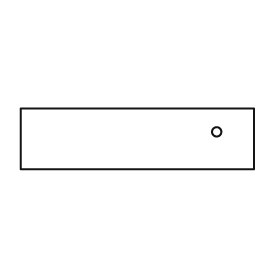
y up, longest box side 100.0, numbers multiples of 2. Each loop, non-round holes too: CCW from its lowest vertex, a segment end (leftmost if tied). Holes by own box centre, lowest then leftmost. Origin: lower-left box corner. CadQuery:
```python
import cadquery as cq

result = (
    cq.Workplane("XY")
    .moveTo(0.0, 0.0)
    .lineTo(100.0, 0.0)
    .lineTo(100.0, 26.0)
    .lineTo(0.0, 26.0)
    .close()
    .moveTo(84.0, 16.0)
    .circle(2.0)
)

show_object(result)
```